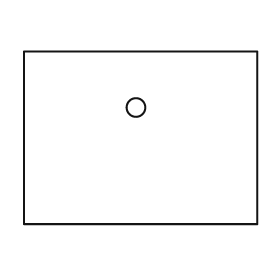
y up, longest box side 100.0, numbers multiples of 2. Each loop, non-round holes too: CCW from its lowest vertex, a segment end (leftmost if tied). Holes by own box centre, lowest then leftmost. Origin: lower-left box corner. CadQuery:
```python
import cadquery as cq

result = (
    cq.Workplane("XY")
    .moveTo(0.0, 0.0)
    .lineTo(100.0, 0.0)
    .lineTo(100.0, 74.0)
    .lineTo(0.0, 74.0)
    .close()
    .moveTo(48.0, 50.0)
    .circle(4.0)
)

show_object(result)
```